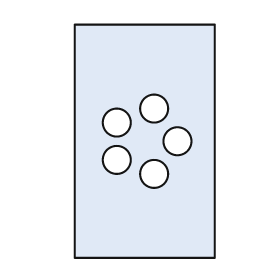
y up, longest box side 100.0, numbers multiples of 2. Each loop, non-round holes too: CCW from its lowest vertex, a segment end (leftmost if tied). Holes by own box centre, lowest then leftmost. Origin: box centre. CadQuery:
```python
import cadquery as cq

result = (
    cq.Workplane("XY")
    .moveTo(-30.0, -50.0)
    .lineTo(30.0, -50.0)
    .lineTo(30.0, 50.0)
    .lineTo(-30.0, 50.0)
    .close()
    .moveTo(4.0, -14.0)
    .circle(6.0)
    .moveTo(-12.0, -8.0)
    .circle(6.0)
    .moveTo(14.0, 0.0)
    .circle(6.0)
    .moveTo(-12.0, 8.0)
    .circle(6.0)
    .moveTo(4.0, 14.0)
    .circle(6.0)
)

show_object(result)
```